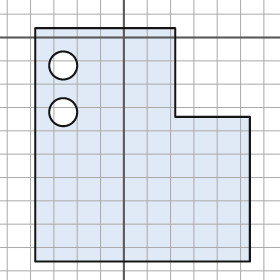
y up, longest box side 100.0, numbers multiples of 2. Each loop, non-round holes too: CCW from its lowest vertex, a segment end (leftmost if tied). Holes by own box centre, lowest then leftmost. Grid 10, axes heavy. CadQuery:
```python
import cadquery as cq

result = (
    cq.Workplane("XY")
    .moveTo(-38.0, -96.0)
    .lineTo(54.0, -96.0)
    .lineTo(54.0, -34.0)
    .lineTo(22.0, -34.0)
    .lineTo(22.0, 4.0)
    .lineTo(-38.0, 4.0)
    .close()
    .moveTo(-26.0, -32.0)
    .circle(6.0)
    .moveTo(-26.0, -12.0)
    .circle(6.0)
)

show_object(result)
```